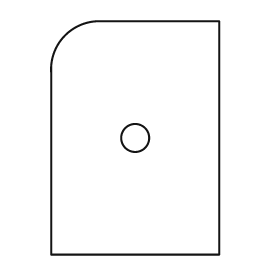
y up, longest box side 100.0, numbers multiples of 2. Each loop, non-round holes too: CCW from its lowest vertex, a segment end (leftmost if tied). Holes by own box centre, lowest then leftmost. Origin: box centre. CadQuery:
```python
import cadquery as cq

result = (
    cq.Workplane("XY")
    .moveTo(-36.0, -50.0)
    .lineTo(36.0, -50.0)
    .lineTo(36.0, 50.0)
    .lineTo(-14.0, 50.0)
    .threePointArc((-30.0, 44.0), (-36.0, 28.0))
    .close()
    .moveTo(0.0, 0.0)
    .circle(6.0)
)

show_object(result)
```